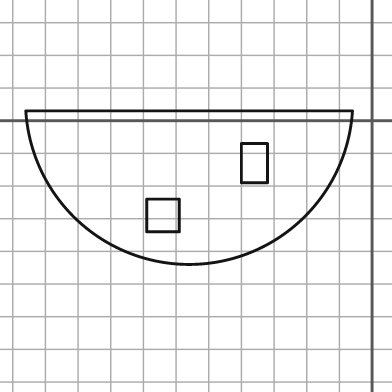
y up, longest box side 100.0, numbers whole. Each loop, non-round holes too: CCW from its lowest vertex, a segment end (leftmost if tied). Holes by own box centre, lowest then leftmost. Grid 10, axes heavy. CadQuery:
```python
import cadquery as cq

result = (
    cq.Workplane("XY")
    .moveTo(-106.0, 3.0)
    .threePointArc((-56.0, -44.0), (-6.0, 3.0))
    .close()
    .moveTo(-69.0, -34.0)
    .lineTo(-59.0, -34.0)
    .lineTo(-59.0, -24.0)
    .lineTo(-69.0, -24.0)
    .close()
    .moveTo(-40.0, -19.0)
    .lineTo(-32.0, -19.0)
    .lineTo(-32.0, -7.0)
    .lineTo(-40.0, -7.0)
    .close()
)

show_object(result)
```